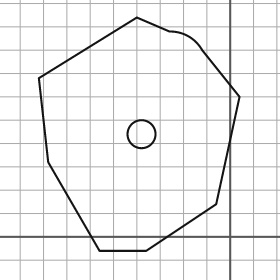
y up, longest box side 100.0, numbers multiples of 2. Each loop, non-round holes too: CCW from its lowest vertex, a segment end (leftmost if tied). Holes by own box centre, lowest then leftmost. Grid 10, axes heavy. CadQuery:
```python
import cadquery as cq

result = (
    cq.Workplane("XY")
    .moveTo(-56.0, -6.0)
    .lineTo(-36.0, -6.0)
    .lineTo(-6.0, 14.0)
    .lineTo(4.0, 60.0)
    .lineTo(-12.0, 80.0)
    .threePointArc((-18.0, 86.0), (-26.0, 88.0))
    .lineTo(-40.0, 94.0)
    .lineTo(-82.0, 68.0)
    .lineTo(-78.0, 32.0)
    .close()
    .moveTo(-38.0, 44.0)
    .circle(6.0)
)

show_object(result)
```